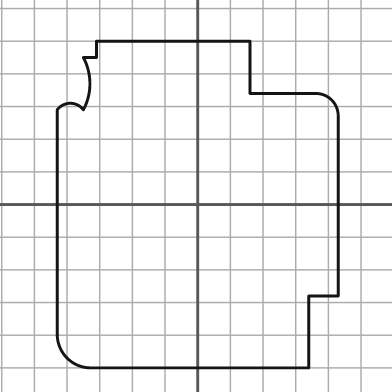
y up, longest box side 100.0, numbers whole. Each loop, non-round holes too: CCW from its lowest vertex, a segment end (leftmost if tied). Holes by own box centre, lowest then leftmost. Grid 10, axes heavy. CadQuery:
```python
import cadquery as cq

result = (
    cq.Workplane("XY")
    .moveTo(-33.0, -50.0)
    .lineTo(34.0, -50.0)
    .lineTo(34.0, -28.0)
    .lineTo(43.0, -28.0)
    .lineTo(43.0, 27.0)
    .threePointArc((41.0, 32.0), (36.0, 34.0))
    .lineTo(16.0, 34.0)
    .lineTo(16.0, 50.0)
    .lineTo(-31.0, 50.0)
    .lineTo(-31.0, 45.0)
    .lineTo(-35.0, 45.0)
    .threePointArc((-33.0, 37.0), (-35.0, 29.0))
    .threePointArc((-39.0, 31.0), (-43.0, 29.0))
    .lineTo(-43.0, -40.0)
    .threePointArc((-40.0, -47.0), (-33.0, -50.0))
    .close()
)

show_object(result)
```